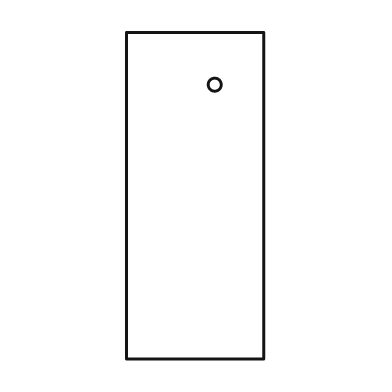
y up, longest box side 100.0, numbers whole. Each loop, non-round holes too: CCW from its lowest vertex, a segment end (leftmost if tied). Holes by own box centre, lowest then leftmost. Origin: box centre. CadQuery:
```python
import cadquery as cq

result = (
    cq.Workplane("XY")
    .moveTo(-21.0, -50.0)
    .lineTo(21.0, -50.0)
    .lineTo(21.0, 50.0)
    .lineTo(-21.0, 50.0)
    .close()
    .moveTo(6.0, 34.0)
    .circle(2.0)
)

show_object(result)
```